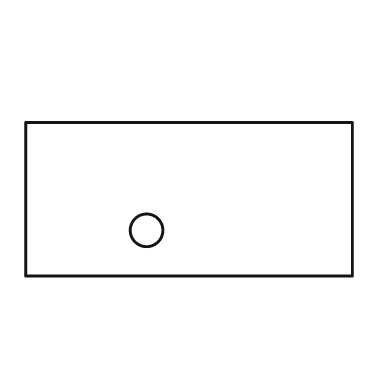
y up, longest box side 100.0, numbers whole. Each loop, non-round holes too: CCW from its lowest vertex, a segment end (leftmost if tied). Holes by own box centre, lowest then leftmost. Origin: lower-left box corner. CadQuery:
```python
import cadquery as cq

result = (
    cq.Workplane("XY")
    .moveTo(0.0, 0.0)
    .lineTo(100.0, 0.0)
    .lineTo(100.0, 47.0)
    .lineTo(0.0, 47.0)
    .close()
    .moveTo(37.0, 14.0)
    .circle(5.0)
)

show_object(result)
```